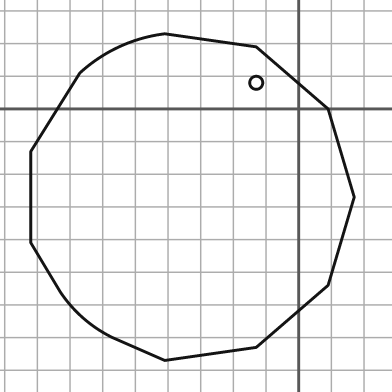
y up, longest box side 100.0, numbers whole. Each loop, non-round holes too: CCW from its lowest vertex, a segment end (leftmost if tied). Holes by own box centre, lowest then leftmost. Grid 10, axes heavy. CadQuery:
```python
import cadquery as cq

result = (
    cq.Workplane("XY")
    .moveTo(-41.0, -77.0)
    .lineTo(-13.0, -73.0)
    .lineTo(9.0, -54.0)
    .lineTo(17.0, -27.0)
    .lineTo(9.0, 0.0)
    .lineTo(-13.0, 19.0)
    .lineTo(-41.0, 23.0)
    .threePointArc((-55.0, 19.0), (-67.0, 11.0))
    .lineTo(-82.0, -13.0)
    .lineTo(-82.0, -41.0)
    .lineTo(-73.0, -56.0)
    .threePointArc((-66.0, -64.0), (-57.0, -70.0))
    .close()
    .moveTo(-13.0, 8.0)
    .circle(2.0)
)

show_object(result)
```